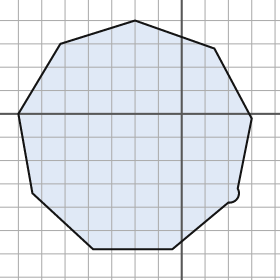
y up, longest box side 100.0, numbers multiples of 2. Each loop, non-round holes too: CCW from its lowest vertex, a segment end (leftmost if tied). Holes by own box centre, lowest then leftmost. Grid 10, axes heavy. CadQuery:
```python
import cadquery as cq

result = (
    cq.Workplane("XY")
    .moveTo(-38.0, -58.0)
    .lineTo(-4.0, -58.0)
    .lineTo(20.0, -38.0)
    .threePointArc((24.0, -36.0), (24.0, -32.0))
    .lineTo(30.0, -2.0)
    .lineTo(14.0, 28.0)
    .lineTo(-20.0, 40.0)
    .lineTo(-52.0, 30.0)
    .lineTo(-70.0, 0.0)
    .lineTo(-64.0, -34.0)
    .close()
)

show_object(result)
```